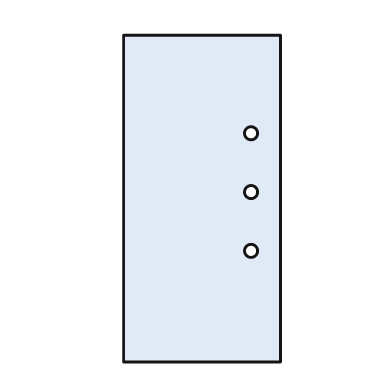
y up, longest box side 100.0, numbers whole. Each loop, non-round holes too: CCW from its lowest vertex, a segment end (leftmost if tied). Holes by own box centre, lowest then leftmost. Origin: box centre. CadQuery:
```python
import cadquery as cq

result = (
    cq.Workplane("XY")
    .moveTo(-24.0, -50.0)
    .lineTo(24.0, -50.0)
    .lineTo(24.0, 50.0)
    .lineTo(-24.0, 50.0)
    .close()
    .moveTo(15.0, -16.0)
    .circle(2.0)
    .moveTo(15.0, 2.0)
    .circle(2.0)
    .moveTo(15.0, 20.0)
    .circle(2.0)
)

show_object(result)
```